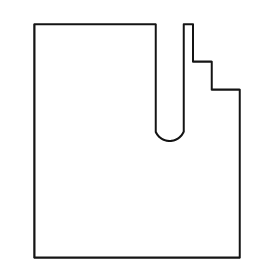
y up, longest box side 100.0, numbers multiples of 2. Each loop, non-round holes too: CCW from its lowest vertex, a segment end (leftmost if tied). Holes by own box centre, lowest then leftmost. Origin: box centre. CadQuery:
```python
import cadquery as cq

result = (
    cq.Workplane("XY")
    .moveTo(-44.0, -50.0)
    .lineTo(44.0, -50.0)
    .lineTo(44.0, 22.0)
    .lineTo(32.0, 22.0)
    .lineTo(32.0, 34.0)
    .lineTo(24.0, 34.0)
    .lineTo(24.0, 50.0)
    .lineTo(20.0, 50.0)
    .lineTo(20.0, 4.0)
    .threePointArc((14.0, 0.0), (8.0, 4.0))
    .lineTo(8.0, 50.0)
    .lineTo(-44.0, 50.0)
    .close()
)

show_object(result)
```